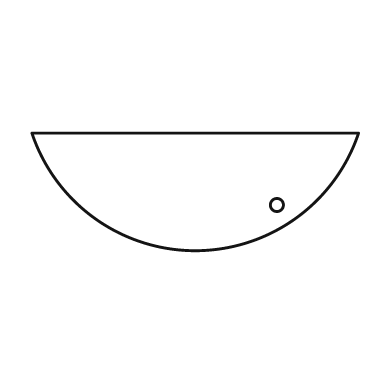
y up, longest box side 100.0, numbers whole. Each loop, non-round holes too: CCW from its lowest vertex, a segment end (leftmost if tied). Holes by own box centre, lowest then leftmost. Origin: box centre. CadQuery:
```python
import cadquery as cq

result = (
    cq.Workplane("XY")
    .moveTo(-50.0, 18.0)
    .threePointArc((0.0, -18.0), (50.0, 18.0))
    .close()
    .moveTo(25.0, -4.0)
    .circle(2.0)
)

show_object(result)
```